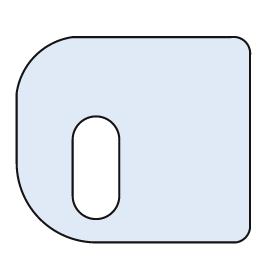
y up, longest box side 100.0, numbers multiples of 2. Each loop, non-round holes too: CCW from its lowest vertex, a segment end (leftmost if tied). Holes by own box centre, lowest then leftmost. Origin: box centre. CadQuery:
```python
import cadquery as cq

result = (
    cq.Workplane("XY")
    .moveTo(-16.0, -44.0)
    .lineTo(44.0, -44.0)
    .threePointArc((48.0, -42.0), (50.0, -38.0))
    .lineTo(50.0, 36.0)
    .threePointArc((48.0, 42.0), (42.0, 44.0))
    .lineTo(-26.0, 44.0)
    .threePointArc((-42.0, 36.0), (-50.0, 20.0))
    .lineTo(-50.0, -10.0)
    .threePointArc((-40.0, -34.0), (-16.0, -44.0))
    .close()
    .moveTo(-26.0, -24.0)
    .threePointArc((-16.0, -34.0), (-6.0, -24.0))
    .lineTo(-6.0, 0.0)
    .threePointArc((-16.0, 10.0), (-26.0, 0.0))
    .close()
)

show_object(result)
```